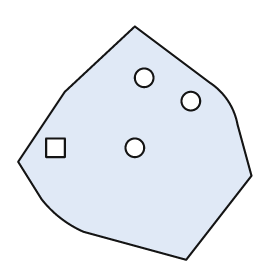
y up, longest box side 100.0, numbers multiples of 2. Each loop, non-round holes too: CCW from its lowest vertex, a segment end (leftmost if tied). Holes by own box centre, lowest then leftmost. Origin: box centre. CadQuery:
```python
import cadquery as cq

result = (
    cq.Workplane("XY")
    .moveTo(22.0, -50.0)
    .lineTo(50.0, -14.0)
    .lineTo(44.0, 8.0)
    .threePointArc((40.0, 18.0), (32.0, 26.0))
    .lineTo(0.0, 50.0)
    .lineTo(-30.0, 22.0)
    .lineTo(-50.0, -8.0)
    .lineTo(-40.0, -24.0)
    .threePointArc((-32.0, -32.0), (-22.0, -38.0))
    .close()
    .moveTo(-38.0, -6.0)
    .lineTo(-30.0, -6.0)
    .lineTo(-30.0, 2.0)
    .lineTo(-38.0, 2.0)
    .close()
    .moveTo(0.0, -2.0)
    .circle(4.0)
    .moveTo(24.0, 18.0)
    .circle(4.0)
    .moveTo(4.0, 28.0)
    .circle(4.0)
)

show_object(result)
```